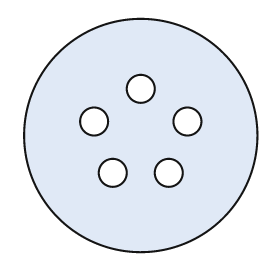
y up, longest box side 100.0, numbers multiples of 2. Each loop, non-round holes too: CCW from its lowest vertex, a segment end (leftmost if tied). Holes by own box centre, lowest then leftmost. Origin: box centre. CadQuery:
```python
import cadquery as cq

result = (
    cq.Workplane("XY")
    .moveTo(0.0, 0.0)
    .circle(50.0)
    .moveTo(-12.0, -16.0)
    .circle(6.0)
    .moveTo(12.0, -16.0)
    .circle(6.0)
    .moveTo(-20.0, 6.0)
    .circle(6.0)
    .moveTo(20.0, 6.0)
    .circle(6.0)
    .moveTo(0.0, 20.0)
    .circle(6.0)
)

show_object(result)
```